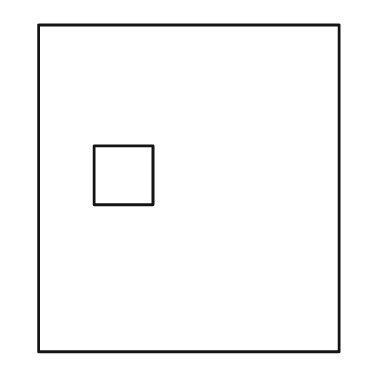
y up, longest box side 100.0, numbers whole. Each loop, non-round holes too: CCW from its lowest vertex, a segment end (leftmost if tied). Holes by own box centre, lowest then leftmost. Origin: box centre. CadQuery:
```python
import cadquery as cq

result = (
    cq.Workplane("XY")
    .moveTo(-46.0, -50.0)
    .lineTo(46.0, -50.0)
    .lineTo(46.0, 50.0)
    .lineTo(-46.0, 50.0)
    .close()
    .moveTo(-29.0, -5.0)
    .lineTo(-11.0, -5.0)
    .lineTo(-11.0, 13.0)
    .lineTo(-29.0, 13.0)
    .close()
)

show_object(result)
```